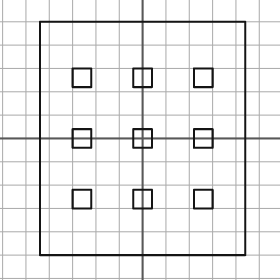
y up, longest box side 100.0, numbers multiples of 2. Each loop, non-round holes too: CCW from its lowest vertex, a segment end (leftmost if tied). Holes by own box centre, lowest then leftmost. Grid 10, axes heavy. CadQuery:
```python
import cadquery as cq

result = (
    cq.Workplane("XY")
    .moveTo(-44.0, -50.0)
    .lineTo(44.0, -50.0)
    .lineTo(44.0, 50.0)
    .lineTo(-44.0, 50.0)
    .close()
    .moveTo(-30.0, -30.0)
    .lineTo(-22.0, -30.0)
    .lineTo(-22.0, -22.0)
    .lineTo(-30.0, -22.0)
    .close()
    .moveTo(-4.0, -30.0)
    .lineTo(4.0, -30.0)
    .lineTo(4.0, -22.0)
    .lineTo(-4.0, -22.0)
    .close()
    .moveTo(22.0, -30.0)
    .lineTo(30.0, -30.0)
    .lineTo(30.0, -22.0)
    .lineTo(22.0, -22.0)
    .close()
    .moveTo(-30.0, -4.0)
    .lineTo(-22.0, -4.0)
    .lineTo(-22.0, 4.0)
    .lineTo(-30.0, 4.0)
    .close()
    .moveTo(-4.0, -4.0)
    .lineTo(4.0, -4.0)
    .lineTo(4.0, 4.0)
    .lineTo(-4.0, 4.0)
    .close()
    .moveTo(22.0, -4.0)
    .lineTo(30.0, -4.0)
    .lineTo(30.0, 4.0)
    .lineTo(22.0, 4.0)
    .close()
    .moveTo(-30.0, 22.0)
    .lineTo(-22.0, 22.0)
    .lineTo(-22.0, 30.0)
    .lineTo(-30.0, 30.0)
    .close()
    .moveTo(-4.0, 22.0)
    .lineTo(4.0, 22.0)
    .lineTo(4.0, 30.0)
    .lineTo(-4.0, 30.0)
    .close()
    .moveTo(22.0, 22.0)
    .lineTo(30.0, 22.0)
    .lineTo(30.0, 30.0)
    .lineTo(22.0, 30.0)
    .close()
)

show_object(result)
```